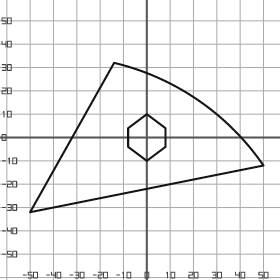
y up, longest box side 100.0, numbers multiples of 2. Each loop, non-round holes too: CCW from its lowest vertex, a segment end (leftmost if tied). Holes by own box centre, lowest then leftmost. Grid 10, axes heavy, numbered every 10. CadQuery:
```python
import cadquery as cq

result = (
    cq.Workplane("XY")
    .moveTo(-50.0, -32.0)
    .lineTo(50.0, -12.0)
    .threePointArc((22.0, 16.0), (-14.0, 32.0))
    .close()
    .moveTo(0.0, -10.0)
    .lineTo(8.0, -4.0)
    .lineTo(8.0, 4.0)
    .lineTo(0.0, 10.0)
    .lineTo(-8.0, 4.0)
    .lineTo(-8.0, -4.0)
    .close()
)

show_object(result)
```